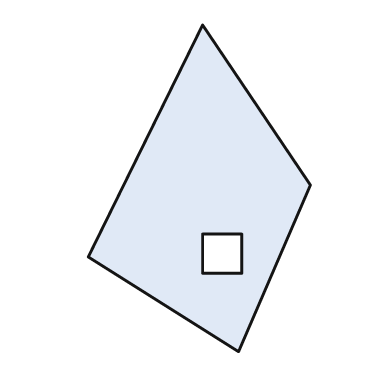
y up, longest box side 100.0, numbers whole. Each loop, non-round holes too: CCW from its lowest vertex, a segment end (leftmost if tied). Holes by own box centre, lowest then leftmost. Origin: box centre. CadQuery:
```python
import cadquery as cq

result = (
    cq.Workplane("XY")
    .moveTo(12.0, -50.0)
    .lineTo(34.0, 1.0)
    .lineTo(1.0, 50.0)
    .lineTo(-34.0, -21.0)
    .close()
    .moveTo(1.0, -26.0)
    .lineTo(13.0, -26.0)
    .lineTo(13.0, -14.0)
    .lineTo(1.0, -14.0)
    .close()
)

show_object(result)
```